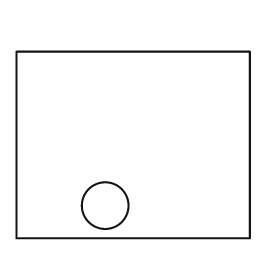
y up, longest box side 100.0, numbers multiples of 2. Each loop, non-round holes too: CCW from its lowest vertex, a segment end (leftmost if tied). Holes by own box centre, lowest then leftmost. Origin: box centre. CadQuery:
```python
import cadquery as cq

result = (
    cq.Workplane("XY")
    .moveTo(-50.0, -40.0)
    .lineTo(50.0, -40.0)
    .lineTo(50.0, 40.0)
    .lineTo(-50.0, 40.0)
    .close()
    .moveTo(-12.0, -26.0)
    .circle(10.0)
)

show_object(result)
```